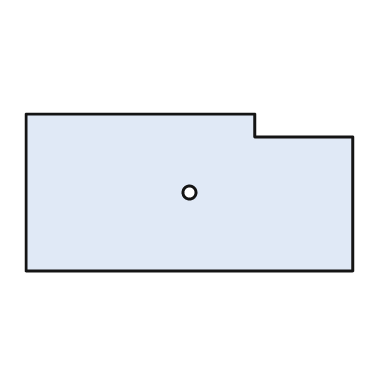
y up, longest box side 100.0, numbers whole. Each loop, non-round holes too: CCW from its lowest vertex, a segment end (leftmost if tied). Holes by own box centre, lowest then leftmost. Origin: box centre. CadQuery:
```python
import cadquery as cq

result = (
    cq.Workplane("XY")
    .moveTo(-50.0, -24.0)
    .lineTo(50.0, -24.0)
    .lineTo(50.0, 17.0)
    .lineTo(20.0, 17.0)
    .lineTo(20.0, 24.0)
    .lineTo(-50.0, 24.0)
    .close()
    .moveTo(0.0, 0.0)
    .circle(2.0)
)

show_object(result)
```